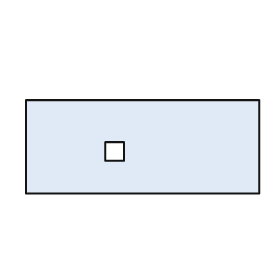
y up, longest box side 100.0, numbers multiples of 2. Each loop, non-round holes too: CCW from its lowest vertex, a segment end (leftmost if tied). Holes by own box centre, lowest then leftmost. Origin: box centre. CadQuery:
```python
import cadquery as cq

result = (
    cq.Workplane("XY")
    .moveTo(-50.0, -20.0)
    .lineTo(50.0, -20.0)
    .lineTo(50.0, 20.0)
    .lineTo(-50.0, 20.0)
    .close()
    .moveTo(-16.0, -6.0)
    .lineTo(-8.0, -6.0)
    .lineTo(-8.0, 2.0)
    .lineTo(-16.0, 2.0)
    .close()
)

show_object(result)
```